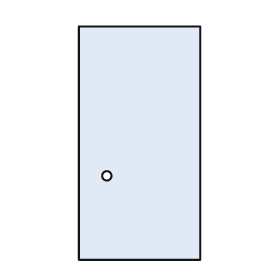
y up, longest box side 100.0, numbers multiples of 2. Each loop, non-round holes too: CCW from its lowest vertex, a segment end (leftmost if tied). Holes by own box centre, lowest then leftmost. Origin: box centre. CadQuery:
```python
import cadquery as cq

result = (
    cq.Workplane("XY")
    .moveTo(-26.0, -50.0)
    .lineTo(26.0, -50.0)
    .lineTo(26.0, 50.0)
    .lineTo(-26.0, 50.0)
    .close()
    .moveTo(-14.0, -14.0)
    .circle(2.0)
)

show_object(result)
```